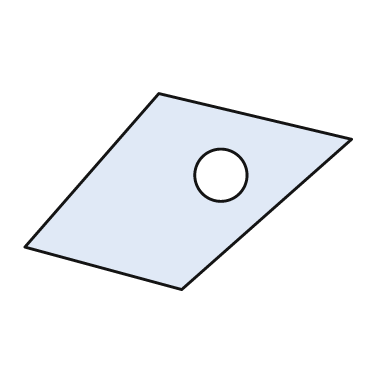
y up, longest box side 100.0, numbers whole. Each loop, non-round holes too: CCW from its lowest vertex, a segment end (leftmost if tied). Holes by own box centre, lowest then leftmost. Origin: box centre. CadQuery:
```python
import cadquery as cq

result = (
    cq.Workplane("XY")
    .moveTo(-2.0, -30.0)
    .lineTo(50.0, 16.0)
    .lineTo(-9.0, 30.0)
    .lineTo(-50.0, -17.0)
    .close()
    .moveTo(10.0, 5.0)
    .circle(8.0)
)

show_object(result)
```